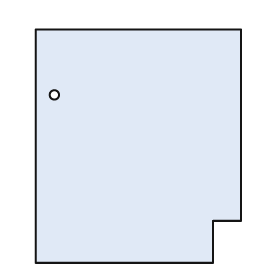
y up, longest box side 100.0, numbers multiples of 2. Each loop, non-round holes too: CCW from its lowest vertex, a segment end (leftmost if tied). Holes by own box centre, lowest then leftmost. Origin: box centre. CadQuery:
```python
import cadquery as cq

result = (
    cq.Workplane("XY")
    .moveTo(-44.0, -50.0)
    .lineTo(32.0, -50.0)
    .lineTo(32.0, -32.0)
    .lineTo(44.0, -32.0)
    .lineTo(44.0, 50.0)
    .lineTo(-44.0, 50.0)
    .close()
    .moveTo(-36.0, 22.0)
    .circle(2.0)
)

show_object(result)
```